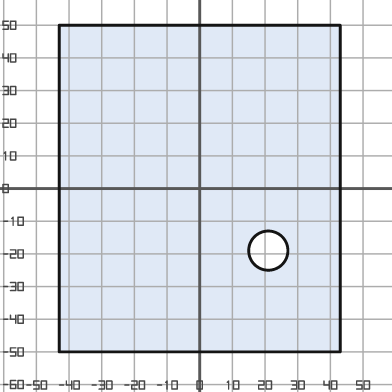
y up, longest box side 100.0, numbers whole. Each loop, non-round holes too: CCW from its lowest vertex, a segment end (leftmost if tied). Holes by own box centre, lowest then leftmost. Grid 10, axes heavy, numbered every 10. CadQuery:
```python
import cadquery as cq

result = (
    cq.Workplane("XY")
    .moveTo(-43.0, -50.0)
    .lineTo(43.0, -50.0)
    .lineTo(43.0, 50.0)
    .lineTo(-43.0, 50.0)
    .close()
    .moveTo(21.0, -19.0)
    .circle(6.0)
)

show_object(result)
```